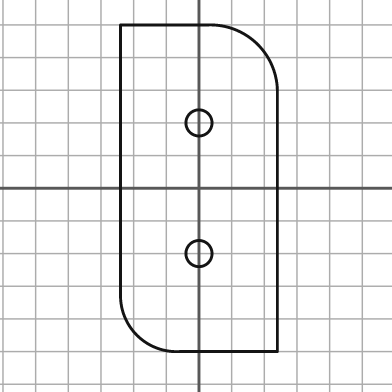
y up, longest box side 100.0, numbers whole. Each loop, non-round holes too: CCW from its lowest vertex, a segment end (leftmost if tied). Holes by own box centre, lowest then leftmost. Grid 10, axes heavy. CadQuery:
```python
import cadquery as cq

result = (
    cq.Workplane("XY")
    .moveTo(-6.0, -50.0)
    .lineTo(24.0, -50.0)
    .lineTo(24.0, 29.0)
    .threePointArc((18.0, 44.0), (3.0, 50.0))
    .lineTo(-24.0, 50.0)
    .lineTo(-24.0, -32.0)
    .threePointArc((-19.0, -45.0), (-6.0, -50.0))
    .close()
    .moveTo(0.0, -20.0)
    .circle(4.0)
    .moveTo(0.0, 20.0)
    .circle(4.0)
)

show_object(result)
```